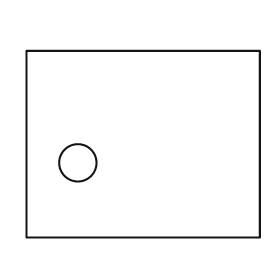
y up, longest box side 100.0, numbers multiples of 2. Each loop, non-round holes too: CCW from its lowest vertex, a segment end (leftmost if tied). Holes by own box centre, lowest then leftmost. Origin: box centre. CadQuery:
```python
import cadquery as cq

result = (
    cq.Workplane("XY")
    .moveTo(-50.0, -40.0)
    .lineTo(50.0, -40.0)
    .lineTo(50.0, 40.0)
    .lineTo(-50.0, 40.0)
    .close()
    .moveTo(-28.0, -8.0)
    .circle(8.0)
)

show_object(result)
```